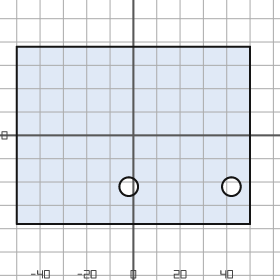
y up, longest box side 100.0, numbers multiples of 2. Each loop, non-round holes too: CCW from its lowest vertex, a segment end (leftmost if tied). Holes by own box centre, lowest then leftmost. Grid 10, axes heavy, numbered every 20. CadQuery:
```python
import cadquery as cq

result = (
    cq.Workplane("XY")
    .moveTo(-50.0, -38.0)
    .lineTo(50.0, -38.0)
    .lineTo(50.0, 38.0)
    .lineTo(-50.0, 38.0)
    .close()
    .moveTo(-2.0, -22.0)
    .circle(4.0)
    .moveTo(42.0, -22.0)
    .circle(4.0)
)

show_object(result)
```